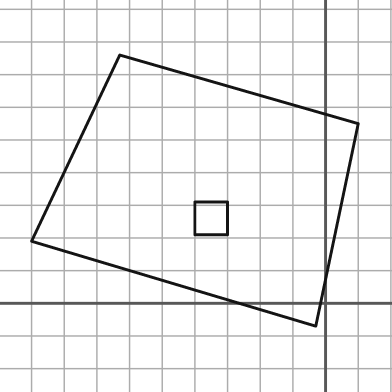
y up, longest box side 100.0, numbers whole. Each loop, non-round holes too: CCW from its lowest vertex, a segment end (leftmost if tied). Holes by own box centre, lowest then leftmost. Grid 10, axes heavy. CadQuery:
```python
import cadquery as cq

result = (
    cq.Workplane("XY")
    .moveTo(-3.0, -7.0)
    .lineTo(10.0, 55.0)
    .lineTo(-63.0, 76.0)
    .lineTo(-90.0, 19.0)
    .close()
    .moveTo(-40.0, 21.0)
    .lineTo(-30.0, 21.0)
    .lineTo(-30.0, 31.0)
    .lineTo(-40.0, 31.0)
    .close()
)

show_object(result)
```